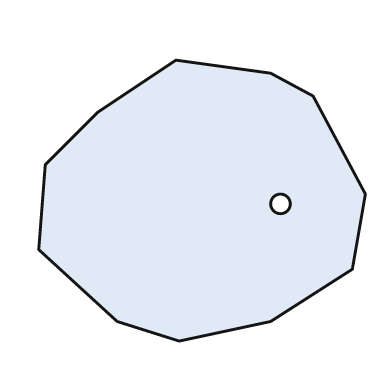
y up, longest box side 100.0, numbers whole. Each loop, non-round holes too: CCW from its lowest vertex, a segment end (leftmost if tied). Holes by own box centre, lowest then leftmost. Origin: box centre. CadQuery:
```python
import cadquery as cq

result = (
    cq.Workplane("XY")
    .moveTo(-7.0, -43.0)
    .lineTo(21.0, -37.0)
    .lineTo(46.0, -21.0)
    .lineTo(50.0, 2.0)
    .lineTo(34.0, 32.0)
    .lineTo(21.0, 39.0)
    .lineTo(-8.0, 43.0)
    .lineTo(-32.0, 27.0)
    .lineTo(-48.0, 11.0)
    .lineTo(-50.0, -15.0)
    .lineTo(-26.0, -37.0)
    .close()
    .moveTo(24.0, -1.0)
    .circle(3.0)
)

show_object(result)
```